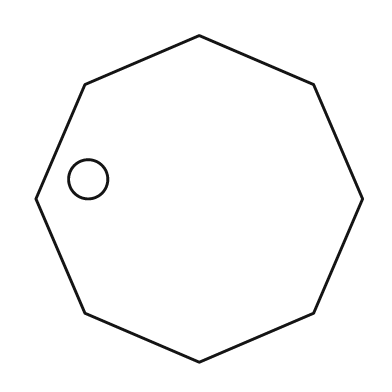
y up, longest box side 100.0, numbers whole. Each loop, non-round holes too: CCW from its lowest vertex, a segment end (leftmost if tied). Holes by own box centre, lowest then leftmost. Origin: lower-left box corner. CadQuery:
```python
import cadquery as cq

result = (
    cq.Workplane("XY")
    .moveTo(50.0, 0.0)
    .lineTo(85.0, 15.0)
    .lineTo(100.0, 50.0)
    .lineTo(85.0, 85.0)
    .lineTo(50.0, 100.0)
    .lineTo(15.0, 85.0)
    .lineTo(0.0, 50.0)
    .lineTo(15.0, 15.0)
    .close()
    .moveTo(16.0, 56.0)
    .circle(6.0)
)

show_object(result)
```